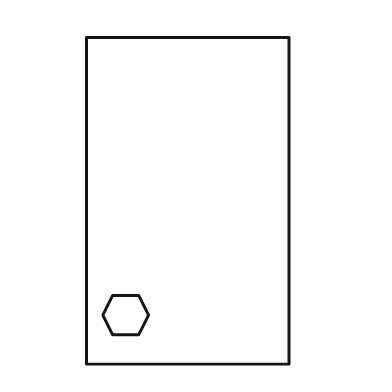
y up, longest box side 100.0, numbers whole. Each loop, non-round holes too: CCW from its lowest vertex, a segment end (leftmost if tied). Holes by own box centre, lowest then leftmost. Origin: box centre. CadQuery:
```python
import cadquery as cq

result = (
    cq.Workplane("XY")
    .moveTo(-31.0, -50.0)
    .lineTo(31.0, -50.0)
    .lineTo(31.0, 50.0)
    .lineTo(-31.0, 50.0)
    .close()
    .moveTo(-23.0, -41.0)
    .lineTo(-15.0, -41.0)
    .lineTo(-12.0, -35.0)
    .lineTo(-15.0, -29.0)
    .lineTo(-23.0, -29.0)
    .lineTo(-26.0, -35.0)
    .close()
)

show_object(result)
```